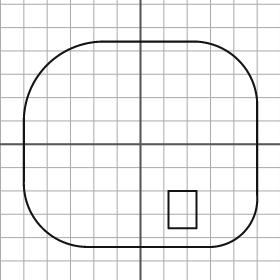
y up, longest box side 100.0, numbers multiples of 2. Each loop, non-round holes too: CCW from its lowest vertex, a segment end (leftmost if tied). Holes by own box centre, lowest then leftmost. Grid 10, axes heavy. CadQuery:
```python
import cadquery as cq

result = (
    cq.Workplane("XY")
    .moveTo(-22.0, -44.0)
    .lineTo(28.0, -44.0)
    .threePointArc((44.0, -38.0), (50.0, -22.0))
    .lineTo(50.0, 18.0)
    .threePointArc((42.0, 36.0), (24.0, 44.0))
    .lineTo(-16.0, 44.0)
    .threePointArc((-40.0, 34.0), (-50.0, 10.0))
    .lineTo(-50.0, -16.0)
    .threePointArc((-42.0, -36.0), (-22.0, -44.0))
    .close()
    .moveTo(12.0, -36.0)
    .lineTo(24.0, -36.0)
    .lineTo(24.0, -20.0)
    .lineTo(12.0, -20.0)
    .close()
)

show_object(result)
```